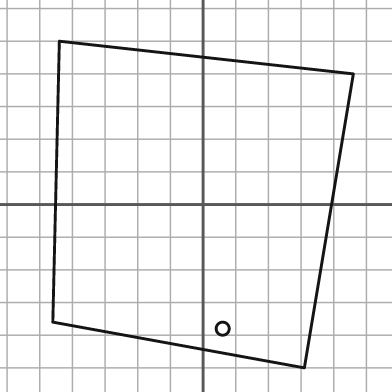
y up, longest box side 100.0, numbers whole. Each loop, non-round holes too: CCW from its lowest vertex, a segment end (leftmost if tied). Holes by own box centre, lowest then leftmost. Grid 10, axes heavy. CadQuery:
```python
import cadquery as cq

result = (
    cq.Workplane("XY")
    .moveTo(31.0, -50.0)
    .lineTo(46.0, 40.0)
    .lineTo(-44.0, 50.0)
    .lineTo(-46.0, -36.0)
    .close()
    .moveTo(6.0, -38.0)
    .circle(2.0)
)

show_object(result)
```